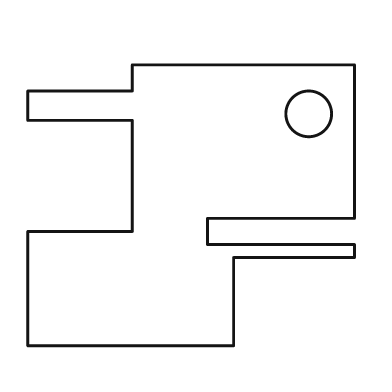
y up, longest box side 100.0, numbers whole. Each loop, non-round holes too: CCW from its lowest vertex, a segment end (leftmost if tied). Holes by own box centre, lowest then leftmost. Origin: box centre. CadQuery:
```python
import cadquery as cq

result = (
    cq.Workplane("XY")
    .moveTo(-50.0, -43.0)
    .lineTo(13.0, -43.0)
    .lineTo(13.0, -16.0)
    .lineTo(50.0, -16.0)
    .lineTo(50.0, -12.0)
    .lineTo(5.0, -12.0)
    .lineTo(5.0, -4.0)
    .lineTo(50.0, -4.0)
    .lineTo(50.0, 43.0)
    .lineTo(-18.0, 43.0)
    .lineTo(-18.0, 35.0)
    .lineTo(-50.0, 35.0)
    .lineTo(-50.0, 26.0)
    .lineTo(-18.0, 26.0)
    .lineTo(-18.0, -8.0)
    .lineTo(-50.0, -8.0)
    .close()
    .moveTo(36.0, 28.0)
    .circle(7.0)
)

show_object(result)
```